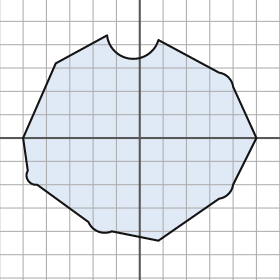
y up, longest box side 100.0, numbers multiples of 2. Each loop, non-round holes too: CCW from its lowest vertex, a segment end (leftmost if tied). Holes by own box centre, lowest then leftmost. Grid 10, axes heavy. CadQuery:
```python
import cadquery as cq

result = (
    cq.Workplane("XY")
    .moveTo(8.0, -44.0)
    .lineTo(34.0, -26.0)
    .threePointArc((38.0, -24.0), (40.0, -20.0))
    .lineTo(50.0, 0.0)
    .lineTo(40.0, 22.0)
    .threePointArc((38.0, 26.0), (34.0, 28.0))
    .lineTo(8.0, 42.0)
    .threePointArc((-4.0, 34.0), (-14.0, 44.0))
    .lineTo(-36.0, 32.0)
    .lineTo(-50.0, 0.0)
    .lineTo(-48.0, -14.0)
    .threePointArc((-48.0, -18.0), (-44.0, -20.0))
    .lineTo(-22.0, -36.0)
    .threePointArc((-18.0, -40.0), (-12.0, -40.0))
    .close()
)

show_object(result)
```